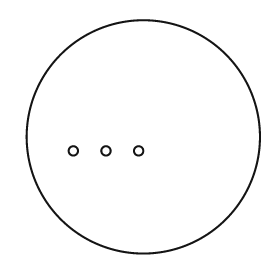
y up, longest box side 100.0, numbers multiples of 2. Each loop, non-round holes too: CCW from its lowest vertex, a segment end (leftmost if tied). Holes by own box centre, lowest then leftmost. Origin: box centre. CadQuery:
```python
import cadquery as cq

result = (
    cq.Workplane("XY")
    .moveTo(0.0, 0.0)
    .circle(50.0)
    .moveTo(-30.0, -6.0)
    .circle(2.0)
    .moveTo(-16.0, -6.0)
    .circle(2.0)
    .moveTo(-2.0, -6.0)
    .circle(2.0)
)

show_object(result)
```